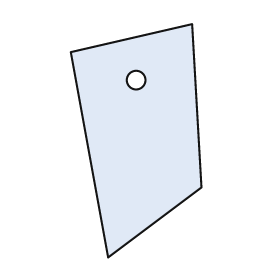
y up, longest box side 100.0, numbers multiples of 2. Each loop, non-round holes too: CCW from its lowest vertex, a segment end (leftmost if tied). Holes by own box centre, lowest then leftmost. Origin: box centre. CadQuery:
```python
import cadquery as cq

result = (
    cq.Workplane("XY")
    .moveTo(-12.0, -50.0)
    .lineTo(28.0, -20.0)
    .lineTo(24.0, 50.0)
    .lineTo(-28.0, 38.0)
    .close()
    .moveTo(0.0, 26.0)
    .circle(4.0)
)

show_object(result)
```